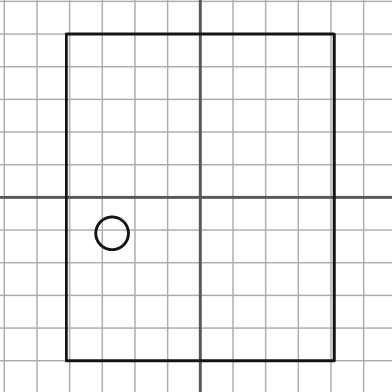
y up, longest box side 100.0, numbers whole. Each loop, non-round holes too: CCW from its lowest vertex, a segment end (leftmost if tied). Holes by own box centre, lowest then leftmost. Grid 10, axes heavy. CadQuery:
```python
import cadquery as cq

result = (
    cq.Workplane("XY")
    .moveTo(-41.0, -50.0)
    .lineTo(41.0, -50.0)
    .lineTo(41.0, 50.0)
    .lineTo(-41.0, 50.0)
    .close()
    .moveTo(-27.0, -11.0)
    .circle(5.0)
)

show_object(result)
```